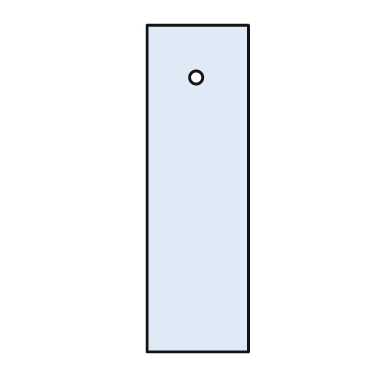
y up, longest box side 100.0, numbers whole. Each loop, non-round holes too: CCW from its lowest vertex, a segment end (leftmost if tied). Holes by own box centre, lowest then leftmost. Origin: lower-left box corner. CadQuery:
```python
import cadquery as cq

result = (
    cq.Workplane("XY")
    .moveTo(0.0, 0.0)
    .lineTo(31.0, 0.0)
    .lineTo(31.0, 100.0)
    .lineTo(0.0, 100.0)
    .close()
    .moveTo(15.0, 84.0)
    .circle(2.0)
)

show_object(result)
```